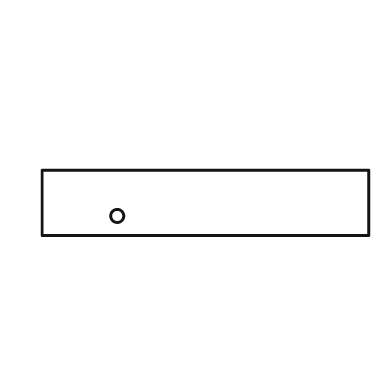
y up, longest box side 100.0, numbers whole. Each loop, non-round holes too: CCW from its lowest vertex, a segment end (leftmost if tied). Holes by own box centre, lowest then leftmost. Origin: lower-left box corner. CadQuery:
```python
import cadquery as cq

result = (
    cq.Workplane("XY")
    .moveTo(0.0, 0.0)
    .lineTo(100.0, 0.0)
    .lineTo(100.0, 20.0)
    .lineTo(0.0, 20.0)
    .close()
    .moveTo(23.0, 6.0)
    .circle(2.0)
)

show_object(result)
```